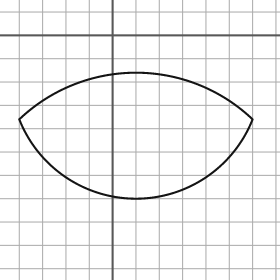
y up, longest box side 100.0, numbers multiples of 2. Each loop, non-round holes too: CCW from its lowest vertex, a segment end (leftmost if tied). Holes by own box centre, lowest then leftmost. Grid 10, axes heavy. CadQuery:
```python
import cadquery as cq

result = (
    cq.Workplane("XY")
    .moveTo(-40.0, -36.0)
    .threePointArc((10.0, -70.0), (60.0, -36.0))
    .threePointArc((10.0, -16.0), (-40.0, -36.0))
    .close()
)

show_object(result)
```